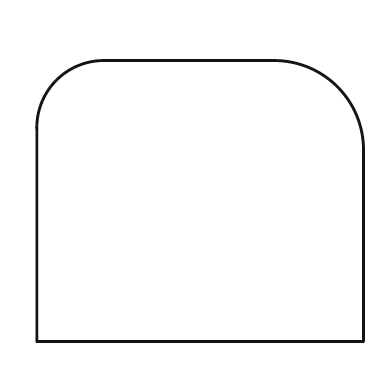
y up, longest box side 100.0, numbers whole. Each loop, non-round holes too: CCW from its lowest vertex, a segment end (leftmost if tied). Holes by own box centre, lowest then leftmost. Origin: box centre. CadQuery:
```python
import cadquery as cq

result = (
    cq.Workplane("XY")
    .moveTo(-50.0, -43.0)
    .lineTo(50.0, -43.0)
    .lineTo(50.0, 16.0)
    .threePointArc((42.0, 35.0), (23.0, 43.0))
    .lineTo(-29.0, 43.0)
    .threePointArc((-44.0, 37.0), (-50.0, 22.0))
    .close()
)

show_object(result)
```